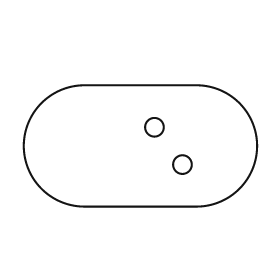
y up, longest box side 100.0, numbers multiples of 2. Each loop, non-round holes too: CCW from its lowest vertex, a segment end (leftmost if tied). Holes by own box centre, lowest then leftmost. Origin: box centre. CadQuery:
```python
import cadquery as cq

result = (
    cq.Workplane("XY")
    .moveTo(-24.0, -26.0)
    .lineTo(24.0, -26.0)
    .threePointArc((50.0, 0.0), (24.0, 26.0))
    .lineTo(-24.0, 26.0)
    .threePointArc((-50.0, 0.0), (-24.0, -26.0))
    .close()
    .moveTo(18.0, -8.0)
    .circle(4.0)
    .moveTo(6.0, 8.0)
    .circle(4.0)
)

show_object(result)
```